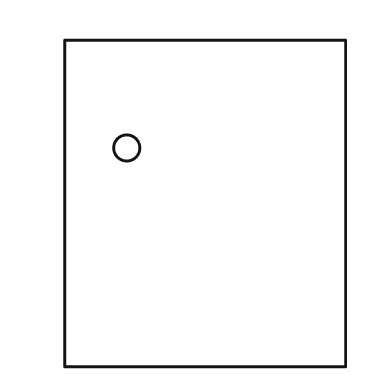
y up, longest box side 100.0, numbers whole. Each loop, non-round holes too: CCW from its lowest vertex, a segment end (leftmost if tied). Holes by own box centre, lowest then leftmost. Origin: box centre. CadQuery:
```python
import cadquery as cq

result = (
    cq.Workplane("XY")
    .moveTo(-43.0, -50.0)
    .lineTo(43.0, -50.0)
    .lineTo(43.0, 50.0)
    .lineTo(-43.0, 50.0)
    .close()
    .moveTo(-24.0, 17.0)
    .circle(4.0)
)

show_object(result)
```